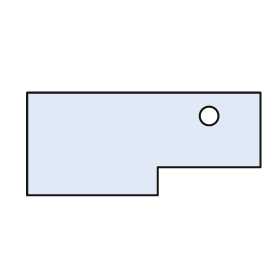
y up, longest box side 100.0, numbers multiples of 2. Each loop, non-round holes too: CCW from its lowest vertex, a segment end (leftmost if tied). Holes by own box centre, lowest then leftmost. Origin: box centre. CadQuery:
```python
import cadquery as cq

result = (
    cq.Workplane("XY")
    .moveTo(-50.0, -22.0)
    .lineTo(6.0, -22.0)
    .lineTo(6.0, -10.0)
    .lineTo(50.0, -10.0)
    .lineTo(50.0, 22.0)
    .lineTo(-50.0, 22.0)
    .close()
    .moveTo(28.0, 12.0)
    .circle(4.0)
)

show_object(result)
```